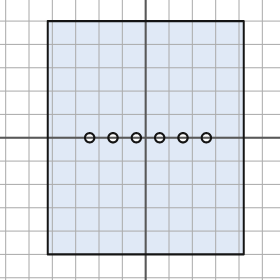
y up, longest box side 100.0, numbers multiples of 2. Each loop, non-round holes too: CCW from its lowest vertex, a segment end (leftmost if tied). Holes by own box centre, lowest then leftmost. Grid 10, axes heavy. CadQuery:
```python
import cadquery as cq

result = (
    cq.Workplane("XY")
    .moveTo(-42.0, -50.0)
    .lineTo(42.0, -50.0)
    .lineTo(42.0, 50.0)
    .lineTo(-42.0, 50.0)
    .close()
    .moveTo(-24.0, 0.0)
    .circle(2.0)
    .moveTo(-14.0, 0.0)
    .circle(2.0)
    .moveTo(-4.0, 0.0)
    .circle(2.0)
    .moveTo(6.0, 0.0)
    .circle(2.0)
    .moveTo(16.0, 0.0)
    .circle(2.0)
    .moveTo(26.0, 0.0)
    .circle(2.0)
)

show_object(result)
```